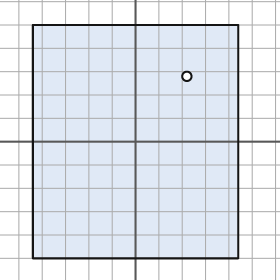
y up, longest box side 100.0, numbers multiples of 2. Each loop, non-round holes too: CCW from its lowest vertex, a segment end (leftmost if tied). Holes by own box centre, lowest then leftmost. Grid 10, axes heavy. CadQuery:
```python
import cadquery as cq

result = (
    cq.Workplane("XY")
    .moveTo(-44.0, -50.0)
    .lineTo(44.0, -50.0)
    .lineTo(44.0, 50.0)
    .lineTo(-44.0, 50.0)
    .close()
    .moveTo(22.0, 28.0)
    .circle(2.0)
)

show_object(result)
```